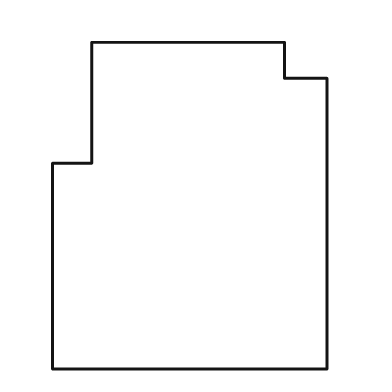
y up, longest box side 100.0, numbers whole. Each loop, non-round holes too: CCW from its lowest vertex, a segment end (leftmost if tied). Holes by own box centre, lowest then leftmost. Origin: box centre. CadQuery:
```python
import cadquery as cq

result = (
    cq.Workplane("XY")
    .moveTo(-42.0, -50.0)
    .lineTo(42.0, -50.0)
    .lineTo(42.0, 39.0)
    .lineTo(29.0, 39.0)
    .lineTo(29.0, 50.0)
    .lineTo(-30.0, 50.0)
    .lineTo(-30.0, 13.0)
    .lineTo(-42.0, 13.0)
    .close()
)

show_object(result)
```